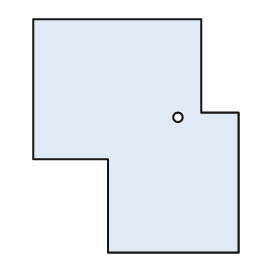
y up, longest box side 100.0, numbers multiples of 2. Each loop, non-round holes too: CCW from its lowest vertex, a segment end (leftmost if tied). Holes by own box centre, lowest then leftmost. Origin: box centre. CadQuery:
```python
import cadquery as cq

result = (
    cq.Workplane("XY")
    .moveTo(-12.0, -50.0)
    .lineTo(44.0, -50.0)
    .lineTo(44.0, 10.0)
    .lineTo(28.0, 10.0)
    .lineTo(28.0, 50.0)
    .lineTo(-44.0, 50.0)
    .lineTo(-44.0, -10.0)
    .lineTo(-12.0, -10.0)
    .close()
    .moveTo(18.0, 8.0)
    .circle(2.0)
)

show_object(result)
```